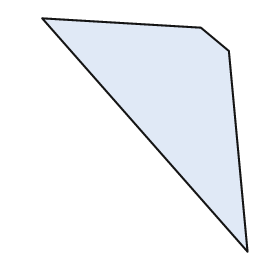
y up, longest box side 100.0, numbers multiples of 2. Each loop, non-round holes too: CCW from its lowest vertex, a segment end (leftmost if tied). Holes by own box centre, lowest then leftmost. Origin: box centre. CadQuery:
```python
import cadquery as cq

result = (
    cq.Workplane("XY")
    .moveTo(44.0, -50.0)
    .lineTo(36.0, 36.0)
    .lineTo(24.0, 46.0)
    .lineTo(-44.0, 50.0)
    .close()
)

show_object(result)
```